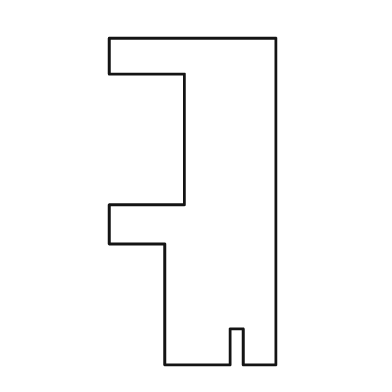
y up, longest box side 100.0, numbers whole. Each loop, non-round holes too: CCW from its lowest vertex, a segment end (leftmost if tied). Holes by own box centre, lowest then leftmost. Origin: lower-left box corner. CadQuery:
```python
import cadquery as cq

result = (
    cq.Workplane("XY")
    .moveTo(17.0, 0.0)
    .lineTo(37.0, 0.0)
    .lineTo(37.0, 11.0)
    .lineTo(41.0, 11.0)
    .lineTo(41.0, 0.0)
    .lineTo(51.0, 0.0)
    .lineTo(51.0, 100.0)
    .lineTo(0.0, 100.0)
    .lineTo(0.0, 89.0)
    .lineTo(23.0, 89.0)
    .lineTo(23.0, 49.0)
    .lineTo(0.0, 49.0)
    .lineTo(0.0, 37.0)
    .lineTo(17.0, 37.0)
    .close()
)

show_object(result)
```